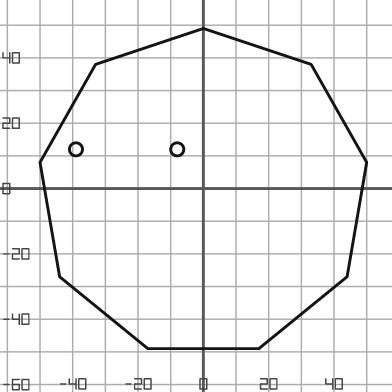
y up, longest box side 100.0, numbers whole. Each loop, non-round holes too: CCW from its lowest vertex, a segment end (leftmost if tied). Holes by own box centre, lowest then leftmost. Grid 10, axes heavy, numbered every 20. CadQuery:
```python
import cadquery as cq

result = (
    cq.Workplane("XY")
    .moveTo(-17.0, -49.0)
    .lineTo(17.0, -49.0)
    .lineTo(44.0, -27.0)
    .lineTo(50.0, 8.0)
    .lineTo(33.0, 38.0)
    .lineTo(0.0, 49.0)
    .lineTo(-33.0, 38.0)
    .lineTo(-50.0, 8.0)
    .lineTo(-44.0, -27.0)
    .close()
    .moveTo(-39.0, 12.0)
    .circle(2.0)
    .moveTo(-8.0, 12.0)
    .circle(2.0)
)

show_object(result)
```